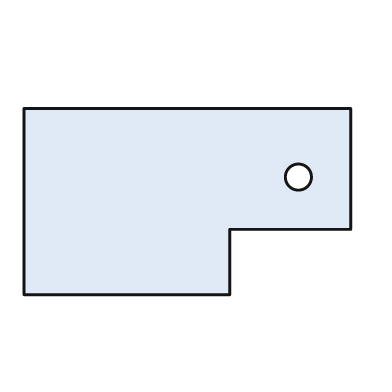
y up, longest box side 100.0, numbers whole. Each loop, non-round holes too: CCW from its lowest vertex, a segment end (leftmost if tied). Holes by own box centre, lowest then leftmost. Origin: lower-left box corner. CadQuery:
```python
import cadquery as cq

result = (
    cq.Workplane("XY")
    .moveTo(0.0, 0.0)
    .lineTo(63.0, 0.0)
    .lineTo(63.0, 20.0)
    .lineTo(100.0, 20.0)
    .lineTo(100.0, 57.0)
    .lineTo(0.0, 57.0)
    .close()
    .moveTo(84.0, 36.0)
    .circle(4.0)
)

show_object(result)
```